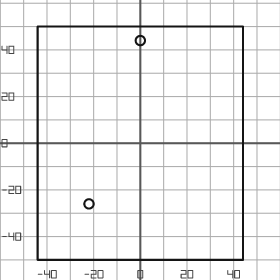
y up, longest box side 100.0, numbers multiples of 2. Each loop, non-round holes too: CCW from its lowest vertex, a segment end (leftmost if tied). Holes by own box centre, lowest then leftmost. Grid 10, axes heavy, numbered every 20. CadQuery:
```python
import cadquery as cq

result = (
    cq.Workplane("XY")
    .moveTo(-44.0, -50.0)
    .lineTo(44.0, -50.0)
    .lineTo(44.0, 50.0)
    .lineTo(-44.0, 50.0)
    .close()
    .moveTo(-22.0, -26.0)
    .circle(2.0)
    .moveTo(0.0, 44.0)
    .circle(2.0)
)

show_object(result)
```